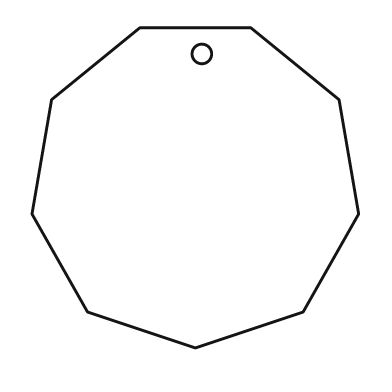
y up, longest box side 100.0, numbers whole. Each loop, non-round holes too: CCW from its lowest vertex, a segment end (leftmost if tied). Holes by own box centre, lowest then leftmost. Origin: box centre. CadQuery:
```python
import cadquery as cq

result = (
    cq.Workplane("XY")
    .moveTo(0.0, -49.0)
    .lineTo(33.0, -38.0)
    .lineTo(50.0, -8.0)
    .lineTo(44.0, 27.0)
    .lineTo(17.0, 49.0)
    .lineTo(-17.0, 49.0)
    .lineTo(-44.0, 27.0)
    .lineTo(-50.0, -8.0)
    .lineTo(-33.0, -38.0)
    .close()
    .moveTo(2.0, 41.0)
    .circle(3.0)
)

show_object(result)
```